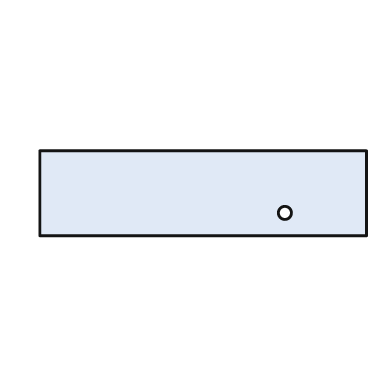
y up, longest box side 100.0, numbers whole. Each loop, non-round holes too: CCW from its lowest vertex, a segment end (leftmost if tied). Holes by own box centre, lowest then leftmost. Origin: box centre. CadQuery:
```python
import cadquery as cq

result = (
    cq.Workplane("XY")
    .moveTo(-50.0, -13.0)
    .lineTo(50.0, -13.0)
    .lineTo(50.0, 13.0)
    .lineTo(-50.0, 13.0)
    .close()
    .moveTo(25.0, -6.0)
    .circle(2.0)
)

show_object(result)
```